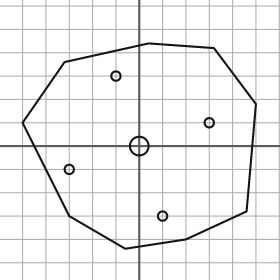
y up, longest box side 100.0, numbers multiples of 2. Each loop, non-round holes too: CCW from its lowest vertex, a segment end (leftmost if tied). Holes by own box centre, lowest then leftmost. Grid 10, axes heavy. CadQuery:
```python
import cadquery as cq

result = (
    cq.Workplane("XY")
    .moveTo(-6.0, -44.0)
    .lineTo(20.0, -40.0)
    .lineTo(46.0, -28.0)
    .lineTo(50.0, 18.0)
    .lineTo(32.0, 42.0)
    .lineTo(4.0, 44.0)
    .lineTo(-32.0, 36.0)
    .lineTo(-50.0, 10.0)
    .lineTo(-30.0, -30.0)
    .close()
    .moveTo(10.0, -30.0)
    .circle(2.0)
    .moveTo(-30.0, -10.0)
    .circle(2.0)
    .moveTo(0.0, 0.0)
    .circle(4.0)
    .moveTo(30.0, 10.0)
    .circle(2.0)
    .moveTo(-10.0, 30.0)
    .circle(2.0)
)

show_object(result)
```